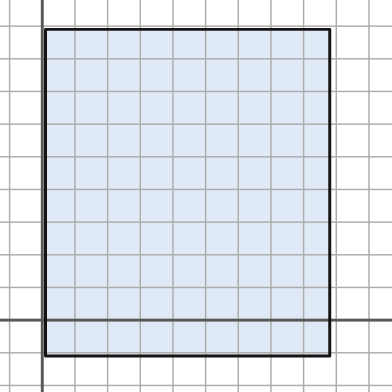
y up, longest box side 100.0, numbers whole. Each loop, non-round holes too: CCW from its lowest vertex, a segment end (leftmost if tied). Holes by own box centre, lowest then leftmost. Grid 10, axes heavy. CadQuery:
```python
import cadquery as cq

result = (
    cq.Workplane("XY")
    .moveTo(1.0, -11.0)
    .lineTo(88.0, -11.0)
    .lineTo(88.0, 89.0)
    .lineTo(1.0, 89.0)
    .close()
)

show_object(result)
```